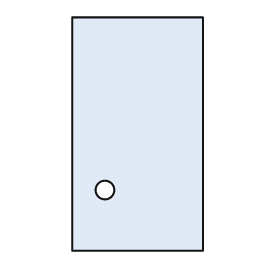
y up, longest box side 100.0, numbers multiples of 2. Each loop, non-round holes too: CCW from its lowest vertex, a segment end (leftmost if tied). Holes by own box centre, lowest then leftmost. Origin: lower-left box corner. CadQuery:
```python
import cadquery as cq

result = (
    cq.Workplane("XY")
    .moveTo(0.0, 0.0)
    .lineTo(56.0, 0.0)
    .lineTo(56.0, 100.0)
    .lineTo(0.0, 100.0)
    .close()
    .moveTo(14.0, 26.0)
    .circle(4.0)
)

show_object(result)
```